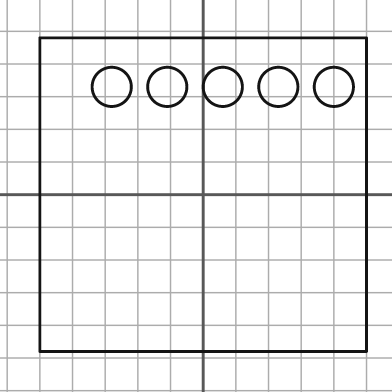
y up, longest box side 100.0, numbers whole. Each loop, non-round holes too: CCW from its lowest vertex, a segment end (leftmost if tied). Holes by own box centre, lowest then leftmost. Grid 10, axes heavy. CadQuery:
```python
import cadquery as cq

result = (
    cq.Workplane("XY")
    .moveTo(-50.0, -48.0)
    .lineTo(50.0, -48.0)
    .lineTo(50.0, 48.0)
    .lineTo(-50.0, 48.0)
    .close()
    .moveTo(-28.0, 33.0)
    .circle(6.0)
    .moveTo(-11.0, 33.0)
    .circle(6.0)
    .moveTo(6.0, 33.0)
    .circle(6.0)
    .moveTo(23.0, 33.0)
    .circle(6.0)
    .moveTo(40.0, 33.0)
    .circle(6.0)
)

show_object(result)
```